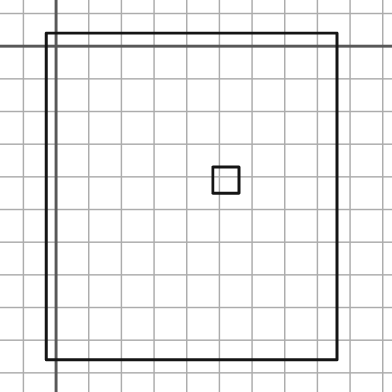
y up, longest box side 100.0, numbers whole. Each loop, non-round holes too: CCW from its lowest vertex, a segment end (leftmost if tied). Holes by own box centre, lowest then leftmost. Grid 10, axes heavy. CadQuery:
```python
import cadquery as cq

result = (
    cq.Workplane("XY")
    .moveTo(-3.0, -96.0)
    .lineTo(86.0, -96.0)
    .lineTo(86.0, 4.0)
    .lineTo(-3.0, 4.0)
    .close()
    .moveTo(48.0, -45.0)
    .lineTo(56.0, -45.0)
    .lineTo(56.0, -37.0)
    .lineTo(48.0, -37.0)
    .close()
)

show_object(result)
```